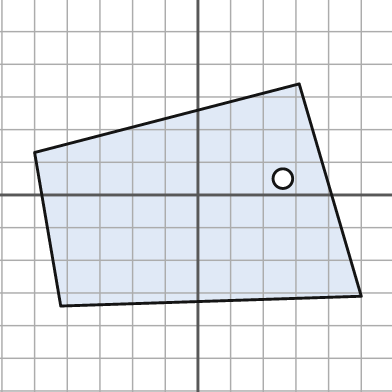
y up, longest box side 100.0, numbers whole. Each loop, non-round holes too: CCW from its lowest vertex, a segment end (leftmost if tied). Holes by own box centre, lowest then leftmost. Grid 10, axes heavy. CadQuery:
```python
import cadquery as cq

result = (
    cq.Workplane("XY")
    .moveTo(-42.0, -34.0)
    .lineTo(50.0, -31.0)
    .lineTo(31.0, 34.0)
    .lineTo(-50.0, 13.0)
    .close()
    .moveTo(26.0, 5.0)
    .circle(3.0)
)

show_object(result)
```